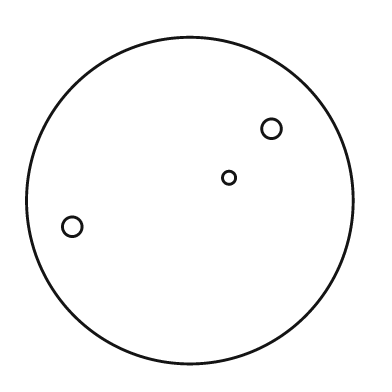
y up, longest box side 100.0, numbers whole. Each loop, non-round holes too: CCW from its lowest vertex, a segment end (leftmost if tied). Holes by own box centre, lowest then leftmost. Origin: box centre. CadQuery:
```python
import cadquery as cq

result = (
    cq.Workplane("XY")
    .moveTo(0.0, 0.0)
    .circle(50.0)
    .moveTo(-36.0, -8.0)
    .circle(3.0)
    .moveTo(12.0, 7.0)
    .circle(2.0)
    .moveTo(25.0, 22.0)
    .circle(3.0)
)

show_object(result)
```